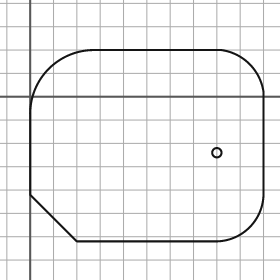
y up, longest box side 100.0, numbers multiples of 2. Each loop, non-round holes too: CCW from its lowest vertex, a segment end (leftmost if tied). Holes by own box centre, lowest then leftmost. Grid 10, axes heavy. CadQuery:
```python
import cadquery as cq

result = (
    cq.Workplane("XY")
    .moveTo(20.0, -62.0)
    .lineTo(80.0, -62.0)
    .threePointArc((94.0, -56.0), (100.0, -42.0))
    .lineTo(100.0, 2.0)
    .threePointArc((94.0, 14.0), (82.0, 20.0))
    .lineTo(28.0, 20.0)
    .threePointArc((8.0, 12.0), (0.0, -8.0))
    .lineTo(0.0, -42.0)
    .close()
    .moveTo(80.0, -24.0)
    .circle(2.0)
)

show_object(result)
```